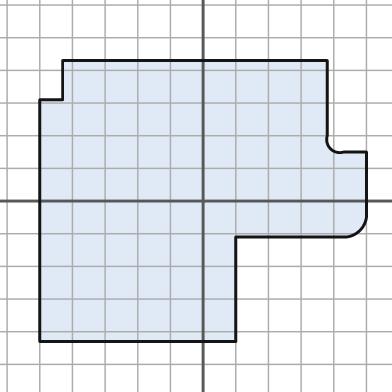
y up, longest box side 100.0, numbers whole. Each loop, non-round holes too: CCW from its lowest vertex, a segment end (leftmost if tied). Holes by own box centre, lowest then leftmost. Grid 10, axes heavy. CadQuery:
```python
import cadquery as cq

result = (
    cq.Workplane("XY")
    .moveTo(-50.0, -43.0)
    .lineTo(10.0, -43.0)
    .lineTo(10.0, -11.0)
    .lineTo(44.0, -11.0)
    .threePointArc((48.0, -9.0), (50.0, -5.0))
    .lineTo(50.0, 15.0)
    .lineTo(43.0, 15.0)
    .threePointArc((39.0, 16.0), (38.0, 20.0))
    .lineTo(38.0, 43.0)
    .lineTo(-43.0, 43.0)
    .lineTo(-43.0, 31.0)
    .lineTo(-50.0, 31.0)
    .close()
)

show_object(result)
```